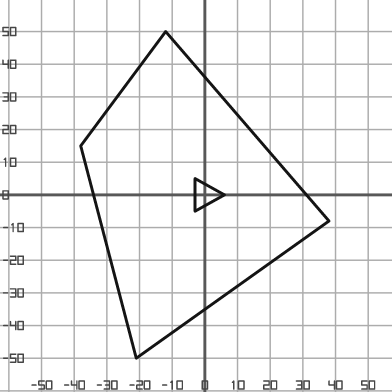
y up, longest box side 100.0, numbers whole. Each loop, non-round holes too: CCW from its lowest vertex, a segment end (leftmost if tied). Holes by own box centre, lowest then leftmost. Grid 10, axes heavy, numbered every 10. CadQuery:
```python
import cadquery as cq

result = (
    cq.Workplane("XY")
    .moveTo(-21.0, -50.0)
    .lineTo(38.0, -8.0)
    .lineTo(-12.0, 50.0)
    .lineTo(-38.0, 15.0)
    .close()
    .moveTo(-3.0, -5.0)
    .lineTo(6.0, 0.0)
    .lineTo(-3.0, 5.0)
    .close()
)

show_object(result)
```